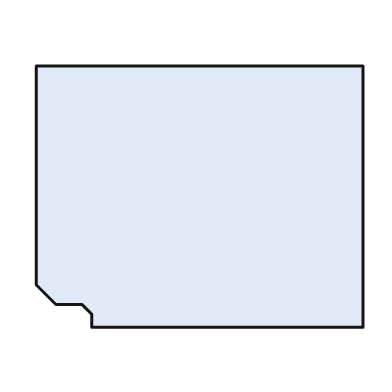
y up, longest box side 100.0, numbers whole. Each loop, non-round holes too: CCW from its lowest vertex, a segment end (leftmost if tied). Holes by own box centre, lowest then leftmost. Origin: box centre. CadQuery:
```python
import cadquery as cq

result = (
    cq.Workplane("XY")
    .moveTo(-33.0, -40.0)
    .lineTo(50.0, -40.0)
    .lineTo(50.0, 40.0)
    .lineTo(-50.0, 40.0)
    .lineTo(-50.0, -27.0)
    .lineTo(-44.0, -33.0)
    .lineTo(-36.0, -33.0)
    .lineTo(-33.0, -36.0)
    .close()
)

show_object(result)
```